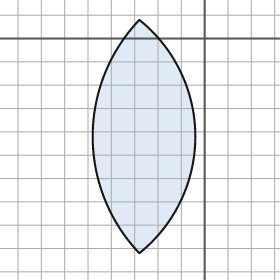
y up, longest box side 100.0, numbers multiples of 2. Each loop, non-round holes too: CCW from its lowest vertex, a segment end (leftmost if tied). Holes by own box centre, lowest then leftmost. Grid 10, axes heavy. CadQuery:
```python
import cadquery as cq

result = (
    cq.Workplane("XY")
    .moveTo(-28.0, -92.0)
    .threePointArc((-4.0, -42.0), (-28.0, 8.0))
    .threePointArc((-48.0, -42.0), (-28.0, -92.0))
    .close()
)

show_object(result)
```